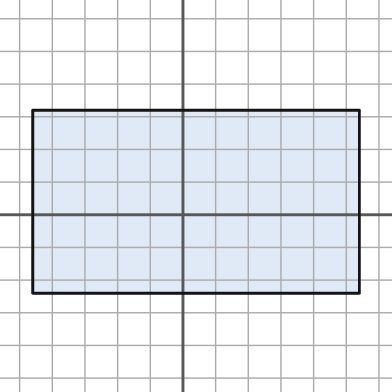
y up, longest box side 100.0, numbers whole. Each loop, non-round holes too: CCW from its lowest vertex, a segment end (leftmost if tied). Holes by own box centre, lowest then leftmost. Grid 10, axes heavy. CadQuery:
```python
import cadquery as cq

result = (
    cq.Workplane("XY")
    .moveTo(-46.0, -24.0)
    .lineTo(54.0, -24.0)
    .lineTo(54.0, 32.0)
    .lineTo(-46.0, 32.0)
    .close()
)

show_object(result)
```